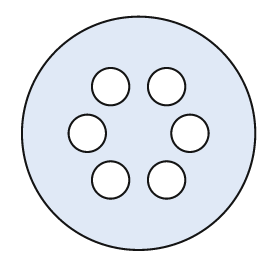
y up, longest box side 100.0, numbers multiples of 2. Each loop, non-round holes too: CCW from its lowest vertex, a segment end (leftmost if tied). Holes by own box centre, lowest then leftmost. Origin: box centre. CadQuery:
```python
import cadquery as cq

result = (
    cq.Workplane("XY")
    .moveTo(0.0, 0.0)
    .circle(50.0)
    .moveTo(-12.0, -20.0)
    .circle(8.0)
    .moveTo(12.0, -20.0)
    .circle(8.0)
    .moveTo(-22.0, 0.0)
    .circle(8.0)
    .moveTo(22.0, 0.0)
    .circle(8.0)
    .moveTo(-12.0, 20.0)
    .circle(8.0)
    .moveTo(12.0, 20.0)
    .circle(8.0)
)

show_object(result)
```